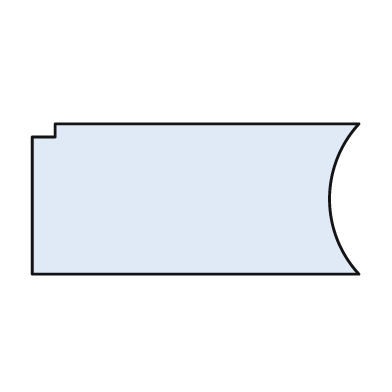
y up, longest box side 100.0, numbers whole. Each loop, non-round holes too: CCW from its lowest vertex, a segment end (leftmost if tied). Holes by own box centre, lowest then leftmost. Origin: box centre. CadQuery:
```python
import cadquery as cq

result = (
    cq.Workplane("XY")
    .moveTo(-50.0, -23.0)
    .lineTo(50.0, -23.0)
    .threePointArc((41.0, 0.0), (50.0, 23.0))
    .lineTo(-43.0, 23.0)
    .lineTo(-43.0, 19.0)
    .lineTo(-50.0, 19.0)
    .close()
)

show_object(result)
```